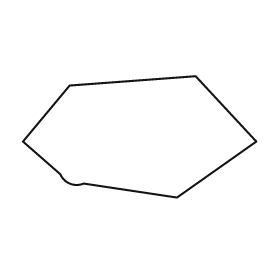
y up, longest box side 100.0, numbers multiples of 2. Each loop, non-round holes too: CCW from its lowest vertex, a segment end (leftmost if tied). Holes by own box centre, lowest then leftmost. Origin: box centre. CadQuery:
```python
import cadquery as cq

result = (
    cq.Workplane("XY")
    .moveTo(16.0, -26.0)
    .lineTo(50.0, -2.0)
    .lineTo(24.0, 26.0)
    .lineTo(-30.0, 22.0)
    .lineTo(-50.0, -2.0)
    .lineTo(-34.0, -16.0)
    .threePointArc((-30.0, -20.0), (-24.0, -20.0))
    .close()
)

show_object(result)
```